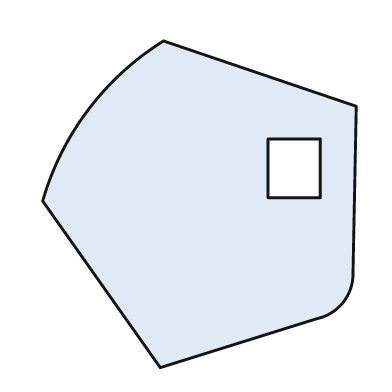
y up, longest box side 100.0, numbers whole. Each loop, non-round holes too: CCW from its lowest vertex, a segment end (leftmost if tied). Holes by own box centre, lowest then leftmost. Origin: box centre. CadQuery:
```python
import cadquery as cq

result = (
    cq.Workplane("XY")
    .moveTo(-12.0, -50.0)
    .lineTo(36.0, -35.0)
    .threePointArc((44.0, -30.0), (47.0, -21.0))
    .lineTo(48.0, 30.0)
    .lineTo(-11.0, 50.0)
    .threePointArc((-34.0, 29.0), (-48.0, 1.0))
    .close()
    .moveTo(21.0, 2.0)
    .lineTo(37.0, 2.0)
    .lineTo(37.0, 20.0)
    .lineTo(21.0, 20.0)
    .close()
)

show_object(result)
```